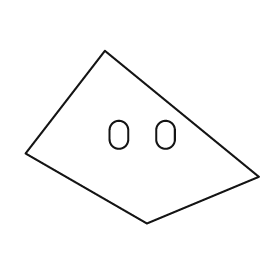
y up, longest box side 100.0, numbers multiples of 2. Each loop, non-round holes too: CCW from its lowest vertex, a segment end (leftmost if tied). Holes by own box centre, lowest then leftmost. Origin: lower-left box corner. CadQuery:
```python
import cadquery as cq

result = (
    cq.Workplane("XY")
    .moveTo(52.0, 0.0)
    .lineTo(100.0, 20.0)
    .lineTo(34.0, 74.0)
    .lineTo(0.0, 30.0)
    .close()
    .moveTo(36.0, 36.0)
    .threePointArc((40.0, 32.0), (44.0, 36.0))
    .lineTo(44.0, 40.0)
    .threePointArc((40.0, 44.0), (36.0, 40.0))
    .close()
    .moveTo(56.0, 36.0)
    .threePointArc((60.0, 32.0), (64.0, 36.0))
    .lineTo(64.0, 40.0)
    .threePointArc((60.0, 44.0), (56.0, 40.0))
    .close()
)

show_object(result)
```